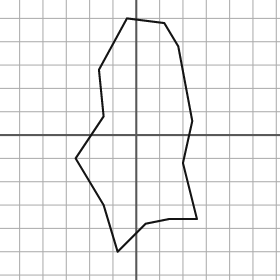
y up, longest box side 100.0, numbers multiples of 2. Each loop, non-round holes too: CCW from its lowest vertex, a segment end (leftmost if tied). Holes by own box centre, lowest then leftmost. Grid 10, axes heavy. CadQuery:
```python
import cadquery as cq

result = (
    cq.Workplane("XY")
    .moveTo(-8.0, -50.0)
    .lineTo(4.0, -38.0)
    .lineTo(14.0, -36.0)
    .lineTo(26.0, -36.0)
    .lineTo(20.0, -12.0)
    .lineTo(24.0, 6.0)
    .lineTo(18.0, 38.0)
    .lineTo(12.0, 48.0)
    .lineTo(-4.0, 50.0)
    .lineTo(-16.0, 28.0)
    .lineTo(-14.0, 8.0)
    .lineTo(-26.0, -10.0)
    .lineTo(-14.0, -30.0)
    .close()
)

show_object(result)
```